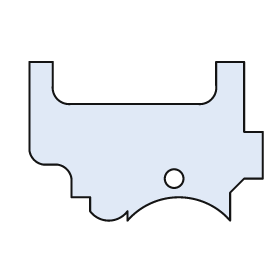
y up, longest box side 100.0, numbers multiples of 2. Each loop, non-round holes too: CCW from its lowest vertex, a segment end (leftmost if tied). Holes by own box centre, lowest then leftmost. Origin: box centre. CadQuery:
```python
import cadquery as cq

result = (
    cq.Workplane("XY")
    .moveTo(-8.0, -34.0)
    .threePointArc((14.0, -24.0), (36.0, -34.0))
    .lineTo(36.0, -22.0)
    .lineTo(42.0, -16.0)
    .lineTo(50.0, -16.0)
    .lineTo(50.0, 4.0)
    .lineTo(42.0, 4.0)
    .lineTo(42.0, 34.0)
    .lineTo(30.0, 34.0)
    .lineTo(30.0, 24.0)
    .threePointArc((28.0, 18.0), (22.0, 16.0))
    .lineTo(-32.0, 16.0)
    .threePointArc((-38.0, 18.0), (-40.0, 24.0))
    .lineTo(-40.0, 34.0)
    .lineTo(-50.0, 34.0)
    .lineTo(-50.0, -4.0)
    .threePointArc((-48.0, -8.0), (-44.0, -10.0))
    .lineTo(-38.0, -10.0)
    .threePointArc((-34.0, -12.0), (-32.0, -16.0))
    .lineTo(-32.0, -24.0)
    .lineTo(-24.0, -24.0)
    .lineTo(-24.0, -30.0)
    .threePointArc((-16.0, -34.0), (-8.0, -30.0))
    .close()
    .moveTo(12.0, -16.0)
    .circle(4.0)
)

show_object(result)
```